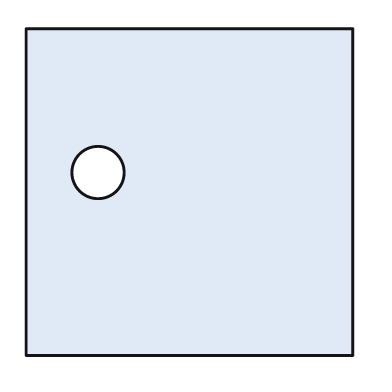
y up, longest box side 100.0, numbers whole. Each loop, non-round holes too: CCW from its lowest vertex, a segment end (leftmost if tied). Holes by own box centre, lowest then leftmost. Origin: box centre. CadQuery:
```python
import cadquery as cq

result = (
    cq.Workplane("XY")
    .moveTo(-50.0, -50.0)
    .lineTo(50.0, -50.0)
    .lineTo(50.0, 50.0)
    .lineTo(-50.0, 50.0)
    .close()
    .moveTo(-28.0, 6.0)
    .circle(8.0)
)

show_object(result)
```